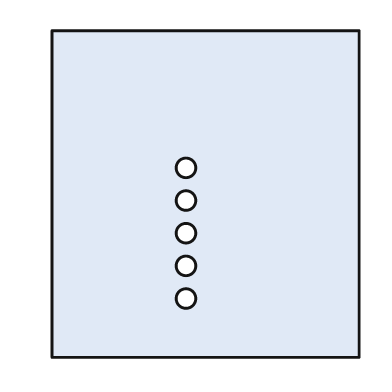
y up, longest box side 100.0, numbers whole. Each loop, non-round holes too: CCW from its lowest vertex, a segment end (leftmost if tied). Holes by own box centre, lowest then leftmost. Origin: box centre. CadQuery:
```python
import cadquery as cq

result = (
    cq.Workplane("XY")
    .moveTo(-47.0, -50.0)
    .lineTo(47.0, -50.0)
    .lineTo(47.0, 50.0)
    .lineTo(-47.0, 50.0)
    .close()
    .moveTo(-6.0, -32.0)
    .circle(3.0)
    .moveTo(-6.0, -22.0)
    .circle(3.0)
    .moveTo(-6.0, -12.0)
    .circle(3.0)
    .moveTo(-6.0, -2.0)
    .circle(3.0)
    .moveTo(-6.0, 8.0)
    .circle(3.0)
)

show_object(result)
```